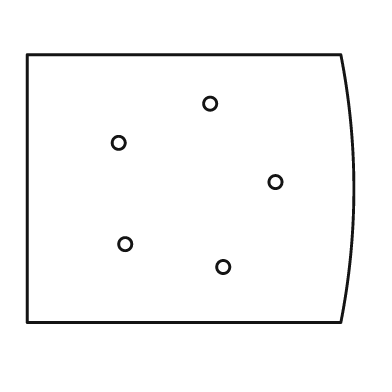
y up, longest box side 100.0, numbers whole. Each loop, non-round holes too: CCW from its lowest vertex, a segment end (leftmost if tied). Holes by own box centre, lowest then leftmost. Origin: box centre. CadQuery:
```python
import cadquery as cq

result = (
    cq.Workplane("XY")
    .moveTo(-50.0, -41.0)
    .lineTo(46.0, -41.0)
    .threePointArc((50.0, 0.0), (46.0, 41.0))
    .lineTo(-50.0, 41.0)
    .close()
    .moveTo(10.0, -24.0)
    .circle(2.0)
    .moveTo(-20.0, -17.0)
    .circle(2.0)
    .moveTo(26.0, 2.0)
    .circle(2.0)
    .moveTo(-22.0, 14.0)
    .circle(2.0)
    .moveTo(6.0, 26.0)
    .circle(2.0)
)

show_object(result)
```